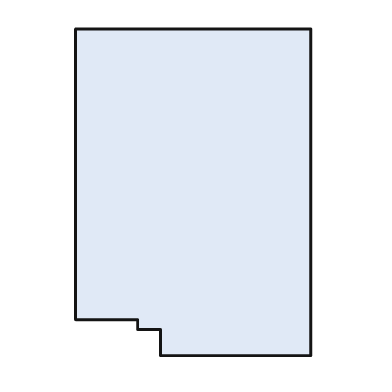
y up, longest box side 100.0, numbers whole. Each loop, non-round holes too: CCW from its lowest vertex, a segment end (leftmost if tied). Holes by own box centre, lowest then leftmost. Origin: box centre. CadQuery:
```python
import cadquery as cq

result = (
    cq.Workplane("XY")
    .moveTo(-10.0, -50.0)
    .lineTo(36.0, -50.0)
    .lineTo(36.0, 50.0)
    .lineTo(-36.0, 50.0)
    .lineTo(-36.0, -39.0)
    .lineTo(-17.0, -39.0)
    .lineTo(-17.0, -42.0)
    .lineTo(-10.0, -42.0)
    .close()
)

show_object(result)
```